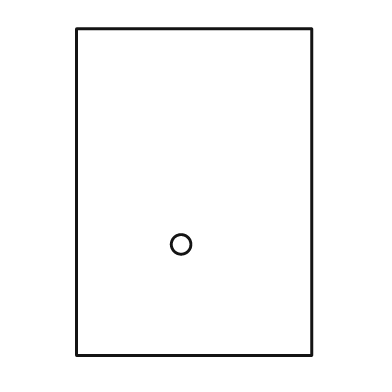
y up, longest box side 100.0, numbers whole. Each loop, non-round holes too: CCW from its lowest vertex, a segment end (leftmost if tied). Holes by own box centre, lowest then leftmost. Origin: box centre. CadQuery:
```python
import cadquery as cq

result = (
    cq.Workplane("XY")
    .moveTo(-36.0, -50.0)
    .lineTo(36.0, -50.0)
    .lineTo(36.0, 50.0)
    .lineTo(-36.0, 50.0)
    .close()
    .moveTo(-4.0, -16.0)
    .circle(3.0)
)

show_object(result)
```